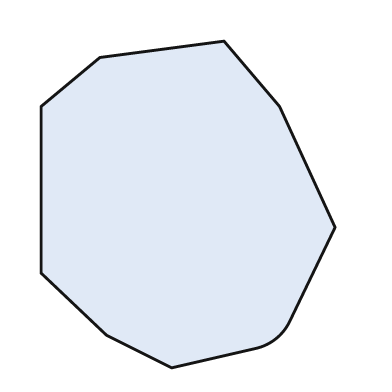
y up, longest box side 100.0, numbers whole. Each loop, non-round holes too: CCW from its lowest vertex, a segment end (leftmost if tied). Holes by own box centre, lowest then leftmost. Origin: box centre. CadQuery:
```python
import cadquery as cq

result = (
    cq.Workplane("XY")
    .moveTo(-5.0, -50.0)
    .lineTo(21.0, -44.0)
    .threePointArc((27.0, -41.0), (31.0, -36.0))
    .lineTo(45.0, -7.0)
    .lineTo(28.0, 30.0)
    .lineTo(11.0, 50.0)
    .lineTo(-27.0, 45.0)
    .lineTo(-45.0, 30.0)
    .lineTo(-45.0, -21.0)
    .lineTo(-25.0, -40.0)
    .close()
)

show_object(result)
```